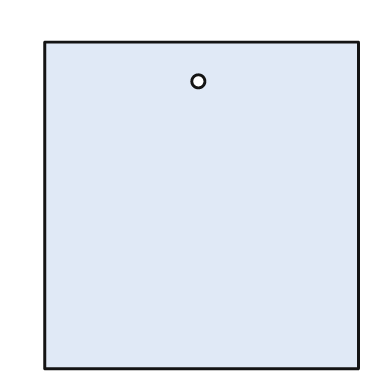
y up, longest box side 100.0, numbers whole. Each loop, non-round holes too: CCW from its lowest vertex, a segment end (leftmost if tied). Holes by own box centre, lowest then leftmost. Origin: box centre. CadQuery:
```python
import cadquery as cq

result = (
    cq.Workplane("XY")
    .moveTo(-48.0, -50.0)
    .lineTo(48.0, -50.0)
    .lineTo(48.0, 50.0)
    .lineTo(-48.0, 50.0)
    .close()
    .moveTo(-1.0, 38.0)
    .circle(2.0)
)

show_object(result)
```